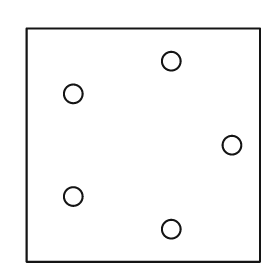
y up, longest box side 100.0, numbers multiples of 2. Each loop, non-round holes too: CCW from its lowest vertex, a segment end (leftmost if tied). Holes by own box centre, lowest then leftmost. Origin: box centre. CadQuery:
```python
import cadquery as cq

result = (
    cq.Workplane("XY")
    .moveTo(-50.0, -50.0)
    .lineTo(50.0, -50.0)
    .lineTo(50.0, 50.0)
    .lineTo(-50.0, 50.0)
    .close()
    .moveTo(12.0, -36.0)
    .circle(4.0)
    .moveTo(-30.0, -22.0)
    .circle(4.0)
    .moveTo(38.0, 0.0)
    .circle(4.0)
    .moveTo(-30.0, 22.0)
    .circle(4.0)
    .moveTo(12.0, 36.0)
    .circle(4.0)
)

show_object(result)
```